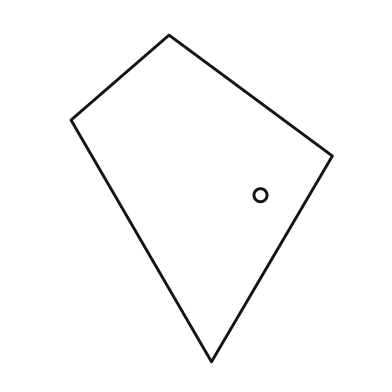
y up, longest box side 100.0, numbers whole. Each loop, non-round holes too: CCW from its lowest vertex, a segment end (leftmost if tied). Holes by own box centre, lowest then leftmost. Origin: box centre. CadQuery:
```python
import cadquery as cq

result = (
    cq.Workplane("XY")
    .moveTo(3.0, -50.0)
    .lineTo(40.0, 13.0)
    .lineTo(-10.0, 50.0)
    .lineTo(-40.0, 24.0)
    .close()
    .moveTo(18.0, 1.0)
    .circle(2.0)
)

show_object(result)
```